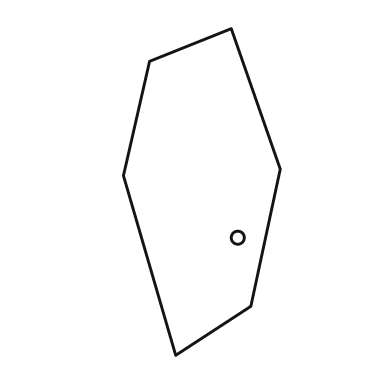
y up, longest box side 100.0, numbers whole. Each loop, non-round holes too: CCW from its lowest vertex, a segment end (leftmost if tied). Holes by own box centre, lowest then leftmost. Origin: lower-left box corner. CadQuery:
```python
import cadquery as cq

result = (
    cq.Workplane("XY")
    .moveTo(16.0, 0.0)
    .lineTo(39.0, 15.0)
    .lineTo(48.0, 57.0)
    .lineTo(33.0, 100.0)
    .lineTo(8.0, 90.0)
    .lineTo(0.0, 55.0)
    .close()
    .moveTo(35.0, 36.0)
    .circle(2.0)
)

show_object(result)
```